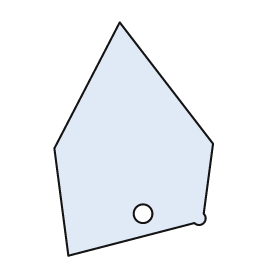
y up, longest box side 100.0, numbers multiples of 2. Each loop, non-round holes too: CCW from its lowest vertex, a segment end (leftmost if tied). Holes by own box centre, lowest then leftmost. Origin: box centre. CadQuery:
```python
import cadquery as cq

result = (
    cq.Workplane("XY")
    .moveTo(-28.0, -50.0)
    .lineTo(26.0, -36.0)
    .threePointArc((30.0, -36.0), (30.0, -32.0))
    .lineTo(34.0, -2.0)
    .lineTo(-6.0, 50.0)
    .lineTo(-34.0, -4.0)
    .close()
    .moveTo(4.0, -32.0)
    .circle(4.0)
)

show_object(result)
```